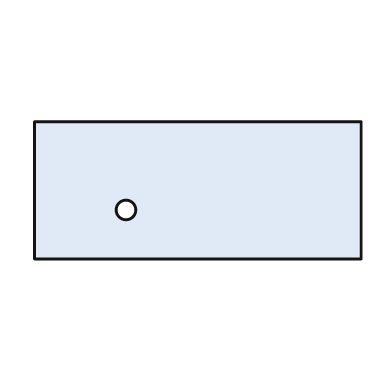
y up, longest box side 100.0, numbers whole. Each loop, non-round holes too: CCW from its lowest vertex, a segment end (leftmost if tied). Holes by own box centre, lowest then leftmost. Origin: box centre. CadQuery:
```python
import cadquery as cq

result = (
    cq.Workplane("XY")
    .moveTo(-50.0, -21.0)
    .lineTo(50.0, -21.0)
    .lineTo(50.0, 21.0)
    .lineTo(-50.0, 21.0)
    .close()
    .moveTo(-22.0, -6.0)
    .circle(3.0)
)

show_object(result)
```